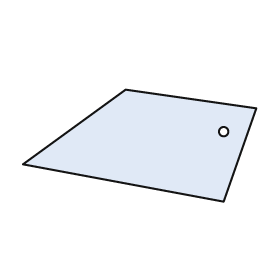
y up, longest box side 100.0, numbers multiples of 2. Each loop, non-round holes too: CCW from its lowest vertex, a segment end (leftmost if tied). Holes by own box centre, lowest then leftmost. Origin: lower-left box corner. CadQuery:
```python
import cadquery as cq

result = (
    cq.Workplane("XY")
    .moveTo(86.0, 0.0)
    .lineTo(100.0, 40.0)
    .lineTo(44.0, 48.0)
    .lineTo(0.0, 16.0)
    .close()
    .moveTo(86.0, 30.0)
    .circle(2.0)
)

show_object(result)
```